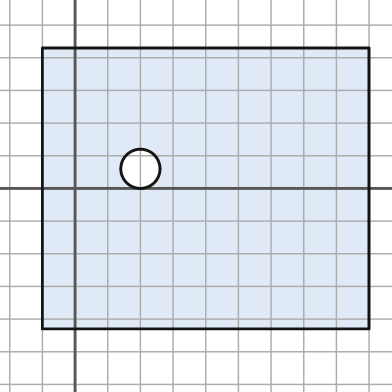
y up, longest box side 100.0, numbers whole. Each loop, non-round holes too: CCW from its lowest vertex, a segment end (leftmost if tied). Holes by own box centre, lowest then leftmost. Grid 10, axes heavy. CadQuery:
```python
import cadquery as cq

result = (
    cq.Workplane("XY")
    .moveTo(-10.0, -43.0)
    .lineTo(90.0, -43.0)
    .lineTo(90.0, 43.0)
    .lineTo(-10.0, 43.0)
    .close()
    .moveTo(20.0, 6.0)
    .circle(6.0)
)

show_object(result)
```